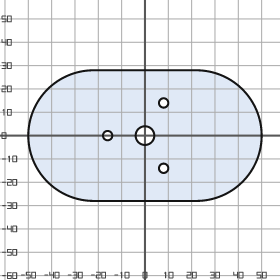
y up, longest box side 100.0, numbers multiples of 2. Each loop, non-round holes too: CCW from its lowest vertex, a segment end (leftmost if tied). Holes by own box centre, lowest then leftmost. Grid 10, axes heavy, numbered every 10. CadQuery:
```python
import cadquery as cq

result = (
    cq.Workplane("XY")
    .moveTo(-22.0, -28.0)
    .lineTo(22.0, -28.0)
    .threePointArc((50.0, 0.0), (22.0, 28.0))
    .lineTo(-22.0, 28.0)
    .threePointArc((-50.0, 0.0), (-22.0, -28.0))
    .close()
    .moveTo(8.0, -14.0)
    .circle(2.0)
    .moveTo(-16.0, 0.0)
    .circle(2.0)
    .moveTo(0.0, 0.0)
    .circle(4.0)
    .moveTo(8.0, 14.0)
    .circle(2.0)
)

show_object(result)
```